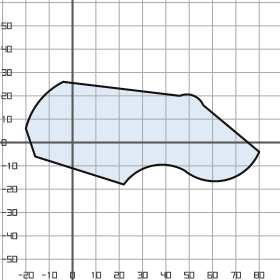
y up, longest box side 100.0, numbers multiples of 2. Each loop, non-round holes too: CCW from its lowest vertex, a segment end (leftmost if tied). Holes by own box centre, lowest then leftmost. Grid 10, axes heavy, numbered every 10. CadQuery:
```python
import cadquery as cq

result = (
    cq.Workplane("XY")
    .moveTo(22.0, -18.0)
    .threePointArc((34.0, -10.0), (48.0, -12.0))
    .threePointArc((66.0, -16.0), (80.0, -4.0))
    .lineTo(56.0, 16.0)
    .threePointArc((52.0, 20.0), (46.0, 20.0))
    .lineTo(-4.0, 26.0)
    .threePointArc((-14.0, 18.0), (-20.0, 6.0))
    .lineTo(-16.0, -6.0)
    .close()
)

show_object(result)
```